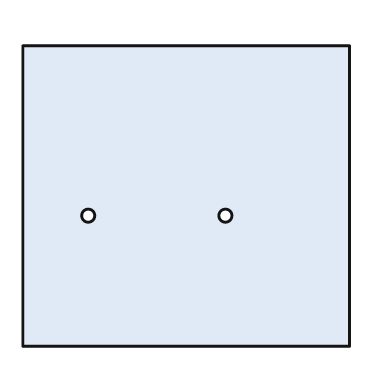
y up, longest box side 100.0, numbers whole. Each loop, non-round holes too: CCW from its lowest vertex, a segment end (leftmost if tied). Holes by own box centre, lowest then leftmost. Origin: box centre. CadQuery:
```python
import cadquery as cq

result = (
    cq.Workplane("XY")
    .moveTo(-50.0, -46.0)
    .lineTo(50.0, -46.0)
    .lineTo(50.0, 46.0)
    .lineTo(-50.0, 46.0)
    .close()
    .moveTo(-30.0, -6.0)
    .circle(2.0)
    .moveTo(12.0, -6.0)
    .circle(2.0)
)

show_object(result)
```